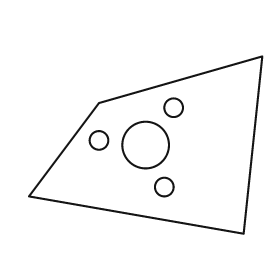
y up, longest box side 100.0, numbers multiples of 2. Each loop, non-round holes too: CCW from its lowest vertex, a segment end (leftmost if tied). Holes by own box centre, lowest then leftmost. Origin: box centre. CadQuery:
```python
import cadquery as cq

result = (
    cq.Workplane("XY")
    .moveTo(42.0, -38.0)
    .lineTo(50.0, 38.0)
    .lineTo(-20.0, 18.0)
    .lineTo(-50.0, -22.0)
    .close()
    .moveTo(8.0, -18.0)
    .circle(4.0)
    .moveTo(0.0, 0.0)
    .circle(10.0)
    .moveTo(-20.0, 2.0)
    .circle(4.0)
    .moveTo(12.0, 16.0)
    .circle(4.0)
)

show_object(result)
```